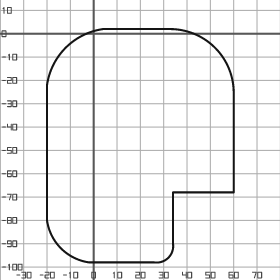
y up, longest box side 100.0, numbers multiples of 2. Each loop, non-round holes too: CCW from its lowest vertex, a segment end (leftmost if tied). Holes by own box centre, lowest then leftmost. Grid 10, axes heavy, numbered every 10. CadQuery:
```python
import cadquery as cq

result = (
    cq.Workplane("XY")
    .moveTo(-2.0, -98.0)
    .lineTo(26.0, -98.0)
    .threePointArc((32.0, -96.0), (34.0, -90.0))
    .lineTo(34.0, -68.0)
    .lineTo(60.0, -68.0)
    .lineTo(60.0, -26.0)
    .threePointArc((52.0, -6.0), (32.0, 2.0))
    .lineTo(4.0, 2.0)
    .threePointArc((-12.0, -6.0), (-20.0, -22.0))
    .lineTo(-20.0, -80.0)
    .threePointArc((-14.0, -92.0), (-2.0, -98.0))
    .close()
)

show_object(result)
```